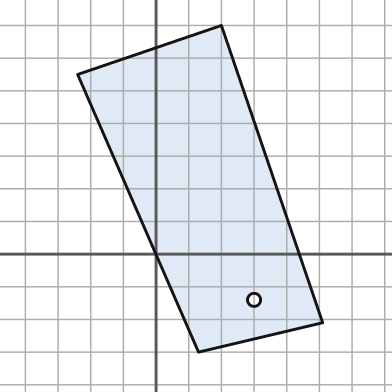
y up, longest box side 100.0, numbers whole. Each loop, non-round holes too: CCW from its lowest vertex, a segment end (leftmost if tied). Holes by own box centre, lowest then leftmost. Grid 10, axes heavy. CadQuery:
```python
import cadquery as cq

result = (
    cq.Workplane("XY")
    .moveTo(13.0, -30.0)
    .lineTo(51.0, -21.0)
    .lineTo(20.0, 70.0)
    .lineTo(-24.0, 55.0)
    .close()
    .moveTo(30.0, -14.0)
    .circle(2.0)
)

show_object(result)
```